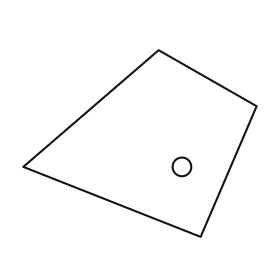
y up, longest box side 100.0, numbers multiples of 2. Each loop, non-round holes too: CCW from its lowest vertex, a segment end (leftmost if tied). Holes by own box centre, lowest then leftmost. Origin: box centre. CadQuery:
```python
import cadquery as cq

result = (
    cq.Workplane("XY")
    .moveTo(26.0, -40.0)
    .lineTo(50.0, 16.0)
    .lineTo(8.0, 40.0)
    .lineTo(-50.0, -10.0)
    .close()
    .moveTo(18.0, -10.0)
    .circle(4.0)
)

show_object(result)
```